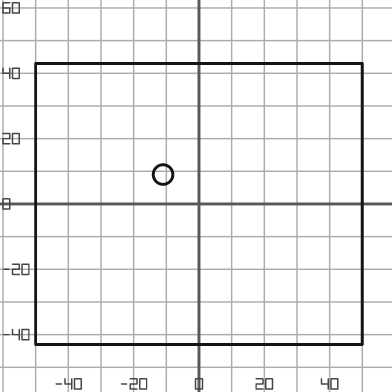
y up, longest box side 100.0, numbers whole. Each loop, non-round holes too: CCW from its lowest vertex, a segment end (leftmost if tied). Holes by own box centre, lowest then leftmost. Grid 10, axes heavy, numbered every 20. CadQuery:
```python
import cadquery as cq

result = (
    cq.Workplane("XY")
    .moveTo(-50.0, -43.0)
    .lineTo(50.0, -43.0)
    .lineTo(50.0, 43.0)
    .lineTo(-50.0, 43.0)
    .close()
    .moveTo(-11.0, 9.0)
    .circle(3.0)
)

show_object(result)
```